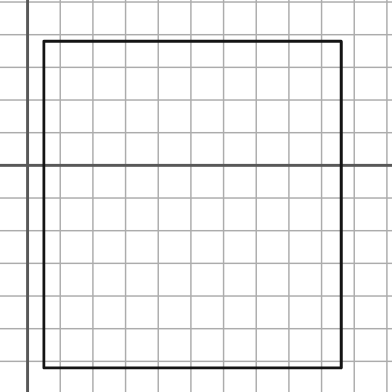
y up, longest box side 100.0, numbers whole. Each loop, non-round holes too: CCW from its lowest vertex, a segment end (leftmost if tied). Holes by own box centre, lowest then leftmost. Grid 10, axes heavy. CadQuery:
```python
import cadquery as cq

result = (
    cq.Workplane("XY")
    .moveTo(5.0, -62.0)
    .lineTo(96.0, -62.0)
    .lineTo(96.0, 38.0)
    .lineTo(5.0, 38.0)
    .close()
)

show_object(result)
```